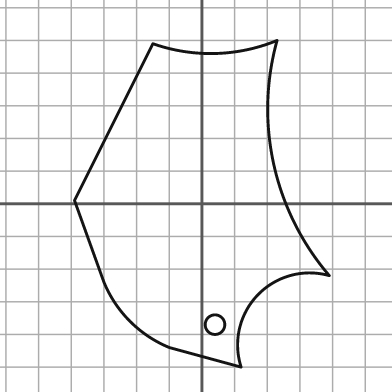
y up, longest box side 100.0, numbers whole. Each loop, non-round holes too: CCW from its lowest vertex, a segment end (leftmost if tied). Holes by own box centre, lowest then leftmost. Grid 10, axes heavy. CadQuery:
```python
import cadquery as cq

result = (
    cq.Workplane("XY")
    .moveTo(12.0, -50.0)
    .threePointArc((17.0, -28.0), (39.0, -22.0))
    .threePointArc((22.0, 12.0), (23.0, 50.0))
    .threePointArc((4.0, 46.0), (-15.0, 49.0))
    .lineTo(-39.0, 1.0)
    .lineTo(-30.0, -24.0)
    .threePointArc((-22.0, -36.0), (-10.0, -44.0))
    .close()
    .moveTo(4.0, -37.0)
    .circle(3.0)
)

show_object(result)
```